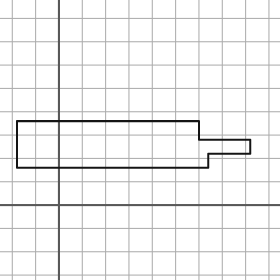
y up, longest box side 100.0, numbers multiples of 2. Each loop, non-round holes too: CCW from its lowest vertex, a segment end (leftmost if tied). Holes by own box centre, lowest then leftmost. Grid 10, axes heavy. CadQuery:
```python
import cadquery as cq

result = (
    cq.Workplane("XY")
    .moveTo(-18.0, 16.0)
    .lineTo(64.0, 16.0)
    .lineTo(64.0, 22.0)
    .lineTo(82.0, 22.0)
    .lineTo(82.0, 28.0)
    .lineTo(60.0, 28.0)
    .lineTo(60.0, 36.0)
    .lineTo(-18.0, 36.0)
    .close()
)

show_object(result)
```